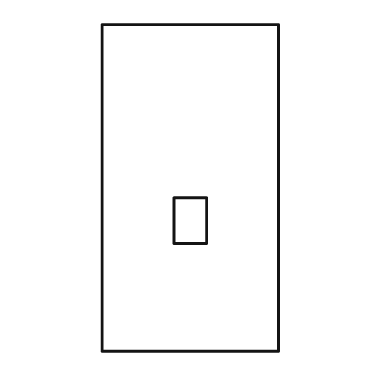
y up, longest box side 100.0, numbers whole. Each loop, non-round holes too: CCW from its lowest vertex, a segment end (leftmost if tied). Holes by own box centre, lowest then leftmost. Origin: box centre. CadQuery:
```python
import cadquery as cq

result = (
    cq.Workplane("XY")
    .moveTo(-27.0, -50.0)
    .lineTo(27.0, -50.0)
    .lineTo(27.0, 50.0)
    .lineTo(-27.0, 50.0)
    .close()
    .moveTo(-5.0, -17.0)
    .lineTo(5.0, -17.0)
    .lineTo(5.0, -3.0)
    .lineTo(-5.0, -3.0)
    .close()
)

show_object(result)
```